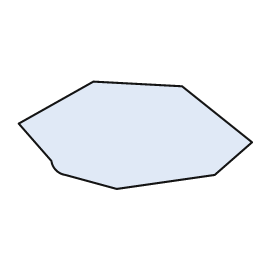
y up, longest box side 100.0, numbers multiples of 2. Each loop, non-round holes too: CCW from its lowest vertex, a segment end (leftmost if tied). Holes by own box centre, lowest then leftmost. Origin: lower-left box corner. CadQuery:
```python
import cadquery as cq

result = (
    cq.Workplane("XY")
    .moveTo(42.0, 0.0)
    .lineTo(84.0, 6.0)
    .lineTo(100.0, 20.0)
    .lineTo(70.0, 44.0)
    .lineTo(32.0, 46.0)
    .lineTo(0.0, 28.0)
    .lineTo(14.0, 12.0)
    .threePointArc((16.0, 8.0), (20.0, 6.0))
    .close()
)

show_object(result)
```